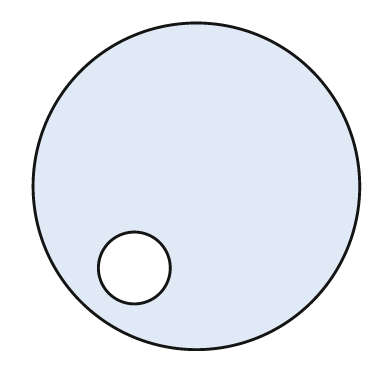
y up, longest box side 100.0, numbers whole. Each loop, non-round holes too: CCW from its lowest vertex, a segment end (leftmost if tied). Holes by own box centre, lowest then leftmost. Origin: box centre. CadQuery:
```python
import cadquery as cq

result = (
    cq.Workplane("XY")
    .moveTo(0.0, 0.0)
    .circle(50.0)
    .moveTo(-19.0, -25.0)
    .circle(11.0)
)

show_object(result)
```